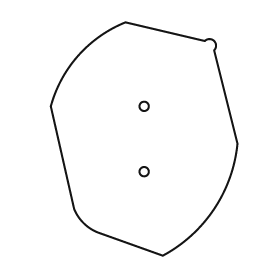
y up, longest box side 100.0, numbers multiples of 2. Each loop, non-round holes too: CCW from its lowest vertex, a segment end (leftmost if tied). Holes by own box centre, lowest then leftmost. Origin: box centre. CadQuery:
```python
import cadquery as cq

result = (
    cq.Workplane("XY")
    .moveTo(8.0, -50.0)
    .threePointArc((30.0, -30.0), (40.0, -2.0))
    .lineTo(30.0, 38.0)
    .threePointArc((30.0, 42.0), (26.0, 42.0))
    .lineTo(-8.0, 50.0)
    .threePointArc((-28.0, 36.0), (-40.0, 14.0))
    .lineTo(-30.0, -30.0)
    .threePointArc((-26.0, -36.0), (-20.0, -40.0))
    .close()
    .moveTo(0.0, -14.0)
    .circle(2.0)
    .moveTo(0.0, 14.0)
    .circle(2.0)
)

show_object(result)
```